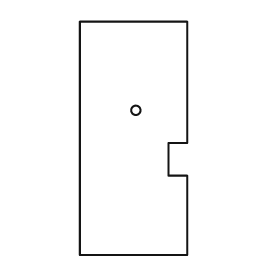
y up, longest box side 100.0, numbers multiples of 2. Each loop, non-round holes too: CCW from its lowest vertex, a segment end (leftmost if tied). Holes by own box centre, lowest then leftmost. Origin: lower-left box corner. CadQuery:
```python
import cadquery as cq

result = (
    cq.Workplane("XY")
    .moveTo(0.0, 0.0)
    .lineTo(46.0, 0.0)
    .lineTo(46.0, 34.0)
    .lineTo(38.0, 34.0)
    .lineTo(38.0, 48.0)
    .lineTo(46.0, 48.0)
    .lineTo(46.0, 100.0)
    .lineTo(0.0, 100.0)
    .close()
    .moveTo(24.0, 62.0)
    .circle(2.0)
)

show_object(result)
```